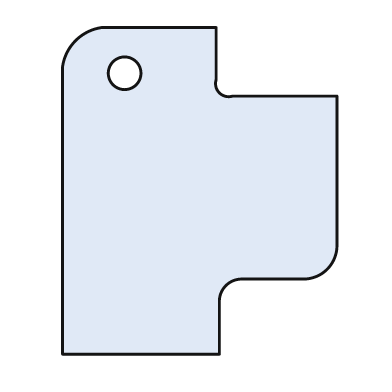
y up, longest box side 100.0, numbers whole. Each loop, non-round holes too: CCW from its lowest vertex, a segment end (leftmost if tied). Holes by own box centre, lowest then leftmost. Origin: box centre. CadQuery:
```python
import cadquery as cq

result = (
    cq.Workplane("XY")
    .moveTo(-42.0, -50.0)
    .lineTo(6.0, -50.0)
    .lineTo(6.0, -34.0)
    .threePointArc((8.0, -29.0), (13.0, -27.0))
    .lineTo(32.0, -27.0)
    .threePointArc((39.0, -24.0), (42.0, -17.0))
    .lineTo(42.0, 29.0)
    .lineTo(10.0, 29.0)
    .threePointArc((6.0, 30.0), (5.0, 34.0))
    .lineTo(5.0, 50.0)
    .lineTo(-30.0, 50.0)
    .threePointArc((-38.0, 46.0), (-42.0, 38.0))
    .close()
    .moveTo(-23.0, 36.0)
    .circle(5.0)
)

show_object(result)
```